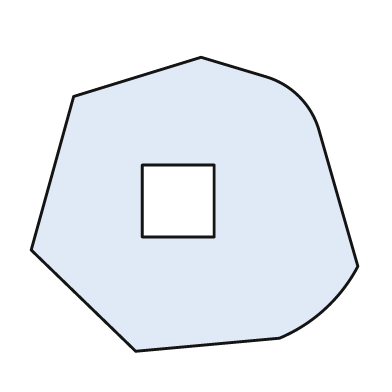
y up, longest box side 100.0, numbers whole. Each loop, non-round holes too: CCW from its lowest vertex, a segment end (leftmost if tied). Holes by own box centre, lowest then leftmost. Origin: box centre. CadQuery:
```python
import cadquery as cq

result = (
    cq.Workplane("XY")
    .moveTo(-18.0, -45.0)
    .lineTo(26.0, -41.0)
    .threePointArc((40.0, -32.0), (50.0, -19.0))
    .lineTo(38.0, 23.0)
    .threePointArc((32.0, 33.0), (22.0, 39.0))
    .lineTo(2.0, 45.0)
    .lineTo(-37.0, 33.0)
    .lineTo(-50.0, -14.0)
    .close()
    .moveTo(-16.0, -10.0)
    .lineTo(6.0, -10.0)
    .lineTo(6.0, 12.0)
    .lineTo(-16.0, 12.0)
    .close()
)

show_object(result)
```